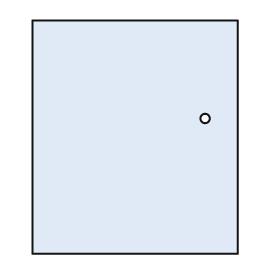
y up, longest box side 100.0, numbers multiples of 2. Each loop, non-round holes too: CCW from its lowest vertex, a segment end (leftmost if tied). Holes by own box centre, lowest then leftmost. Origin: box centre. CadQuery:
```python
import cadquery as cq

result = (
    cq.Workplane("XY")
    .moveTo(-44.0, -50.0)
    .lineTo(44.0, -50.0)
    .lineTo(44.0, 50.0)
    .lineTo(-44.0, 50.0)
    .close()
    .moveTo(30.0, 8.0)
    .circle(2.0)
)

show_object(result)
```